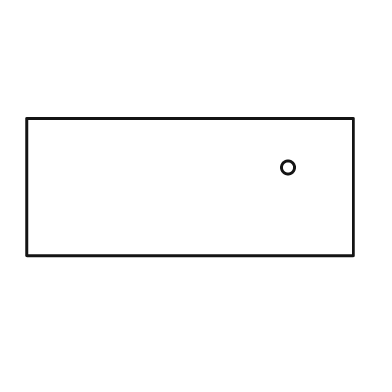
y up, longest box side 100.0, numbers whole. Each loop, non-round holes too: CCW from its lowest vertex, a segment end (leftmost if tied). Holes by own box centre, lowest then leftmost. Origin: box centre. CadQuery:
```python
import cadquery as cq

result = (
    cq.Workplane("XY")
    .moveTo(-50.0, -21.0)
    .lineTo(50.0, -21.0)
    .lineTo(50.0, 21.0)
    .lineTo(-50.0, 21.0)
    .close()
    .moveTo(30.0, 6.0)
    .circle(2.0)
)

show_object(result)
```